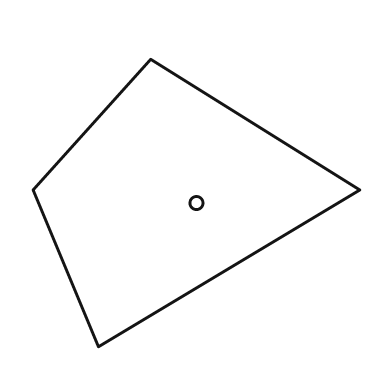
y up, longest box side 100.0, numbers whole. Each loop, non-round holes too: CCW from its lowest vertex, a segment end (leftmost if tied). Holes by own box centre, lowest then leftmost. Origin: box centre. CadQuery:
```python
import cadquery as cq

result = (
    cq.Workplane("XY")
    .moveTo(-30.0, -44.0)
    .lineTo(50.0, 4.0)
    .lineTo(-14.0, 44.0)
    .lineTo(-50.0, 4.0)
    .close()
    .moveTo(0.0, 0.0)
    .circle(2.0)
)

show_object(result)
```